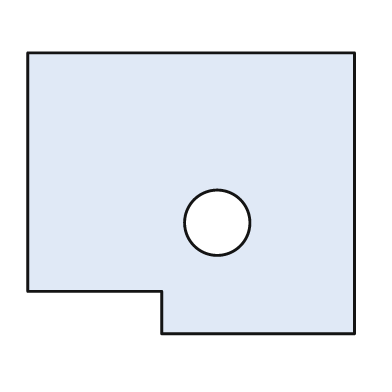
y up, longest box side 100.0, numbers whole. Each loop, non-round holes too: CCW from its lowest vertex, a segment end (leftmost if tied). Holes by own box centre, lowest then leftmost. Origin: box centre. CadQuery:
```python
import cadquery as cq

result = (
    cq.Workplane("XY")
    .moveTo(-9.0, -43.0)
    .lineTo(50.0, -43.0)
    .lineTo(50.0, 43.0)
    .lineTo(-50.0, 43.0)
    .lineTo(-50.0, -30.0)
    .lineTo(-9.0, -30.0)
    .close()
    .moveTo(8.0, -9.0)
    .circle(10.0)
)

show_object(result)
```